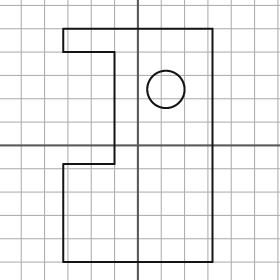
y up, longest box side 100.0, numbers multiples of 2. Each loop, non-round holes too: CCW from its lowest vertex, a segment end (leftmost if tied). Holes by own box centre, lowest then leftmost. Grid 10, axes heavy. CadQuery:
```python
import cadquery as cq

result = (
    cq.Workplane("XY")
    .moveTo(-32.0, -50.0)
    .lineTo(32.0, -50.0)
    .lineTo(32.0, 50.0)
    .lineTo(-32.0, 50.0)
    .lineTo(-32.0, 40.0)
    .lineTo(-10.0, 40.0)
    .lineTo(-10.0, -8.0)
    .lineTo(-32.0, -8.0)
    .close()
    .moveTo(12.0, 24.0)
    .circle(8.0)
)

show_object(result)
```